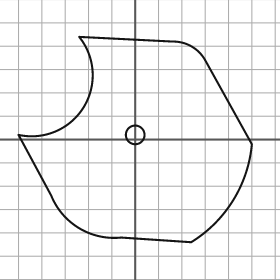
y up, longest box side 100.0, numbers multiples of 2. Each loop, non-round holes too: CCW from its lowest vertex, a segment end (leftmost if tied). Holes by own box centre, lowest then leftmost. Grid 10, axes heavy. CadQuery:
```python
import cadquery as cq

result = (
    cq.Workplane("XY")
    .moveTo(24.0, -44.0)
    .threePointArc((42.0, -26.0), (50.0, -2.0))
    .lineTo(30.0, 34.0)
    .threePointArc((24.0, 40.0), (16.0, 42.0))
    .lineTo(-24.0, 44.0)
    .threePointArc((-22.0, 14.0), (-50.0, 2.0))
    .lineTo(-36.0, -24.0)
    .threePointArc((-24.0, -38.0), (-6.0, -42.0))
    .close()
    .moveTo(0.0, 2.0)
    .circle(4.0)
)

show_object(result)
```